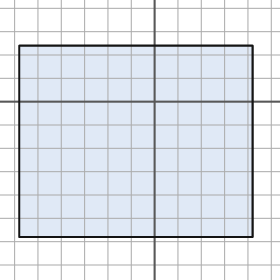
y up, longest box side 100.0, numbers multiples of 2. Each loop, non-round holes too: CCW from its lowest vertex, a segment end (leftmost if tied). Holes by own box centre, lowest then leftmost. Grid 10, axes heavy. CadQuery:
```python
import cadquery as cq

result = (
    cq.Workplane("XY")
    .moveTo(-58.0, -58.0)
    .lineTo(42.0, -58.0)
    .lineTo(42.0, 24.0)
    .lineTo(-58.0, 24.0)
    .close()
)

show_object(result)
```